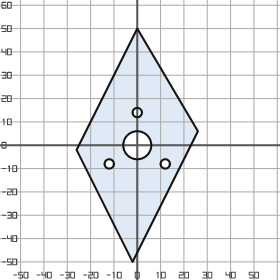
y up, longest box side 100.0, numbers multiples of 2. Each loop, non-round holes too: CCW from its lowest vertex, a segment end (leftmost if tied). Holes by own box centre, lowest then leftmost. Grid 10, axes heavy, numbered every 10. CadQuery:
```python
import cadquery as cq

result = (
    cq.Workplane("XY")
    .moveTo(-2.0, -50.0)
    .lineTo(26.0, 6.0)
    .lineTo(0.0, 50.0)
    .lineTo(-26.0, -2.0)
    .close()
    .moveTo(-12.0, -8.0)
    .circle(2.0)
    .moveTo(12.0, -8.0)
    .circle(2.0)
    .moveTo(0.0, 0.0)
    .circle(6.0)
    .moveTo(0.0, 14.0)
    .circle(2.0)
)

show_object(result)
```